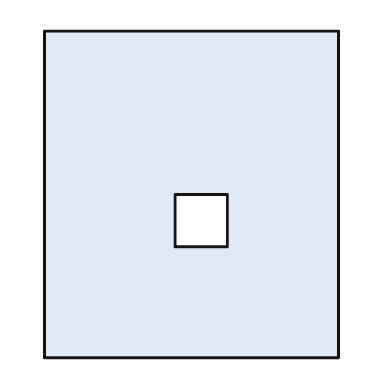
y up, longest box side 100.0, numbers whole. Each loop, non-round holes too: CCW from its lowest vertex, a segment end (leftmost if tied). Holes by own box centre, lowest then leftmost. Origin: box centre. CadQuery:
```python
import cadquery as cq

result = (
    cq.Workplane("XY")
    .moveTo(-45.0, -50.0)
    .lineTo(45.0, -50.0)
    .lineTo(45.0, 50.0)
    .lineTo(-45.0, 50.0)
    .close()
    .moveTo(-5.0, -16.0)
    .lineTo(11.0, -16.0)
    .lineTo(11.0, 0.0)
    .lineTo(-5.0, 0.0)
    .close()
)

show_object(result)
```